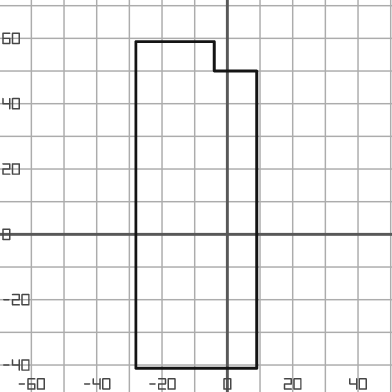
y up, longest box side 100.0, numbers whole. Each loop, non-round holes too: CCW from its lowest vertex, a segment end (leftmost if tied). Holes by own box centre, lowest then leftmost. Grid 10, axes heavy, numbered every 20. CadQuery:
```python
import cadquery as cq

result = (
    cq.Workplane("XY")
    .moveTo(-28.0, -41.0)
    .lineTo(9.0, -41.0)
    .lineTo(9.0, 50.0)
    .lineTo(-4.0, 50.0)
    .lineTo(-4.0, 59.0)
    .lineTo(-28.0, 59.0)
    .close()
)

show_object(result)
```